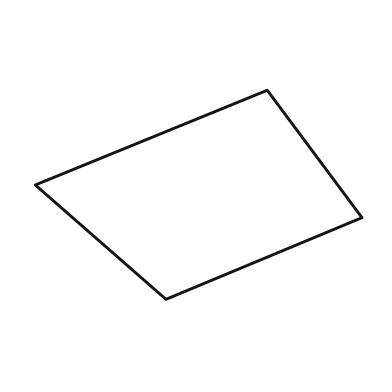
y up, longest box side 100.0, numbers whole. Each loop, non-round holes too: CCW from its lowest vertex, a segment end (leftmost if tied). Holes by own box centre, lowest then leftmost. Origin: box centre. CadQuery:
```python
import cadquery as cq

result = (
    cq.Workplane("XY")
    .moveTo(-10.0, -32.0)
    .lineTo(50.0, -7.0)
    .lineTo(21.0, 32.0)
    .lineTo(-50.0, 3.0)
    .close()
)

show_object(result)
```